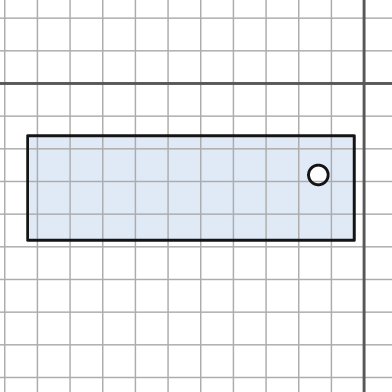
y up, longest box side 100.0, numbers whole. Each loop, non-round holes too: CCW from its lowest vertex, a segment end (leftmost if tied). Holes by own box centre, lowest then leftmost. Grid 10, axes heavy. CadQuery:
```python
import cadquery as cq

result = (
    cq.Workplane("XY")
    .moveTo(-103.0, -48.0)
    .lineTo(-3.0, -48.0)
    .lineTo(-3.0, -16.0)
    .lineTo(-103.0, -16.0)
    .close()
    .moveTo(-14.0, -28.0)
    .circle(3.0)
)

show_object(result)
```